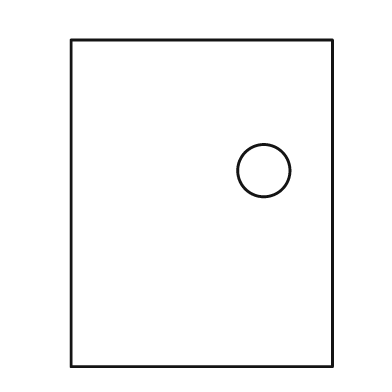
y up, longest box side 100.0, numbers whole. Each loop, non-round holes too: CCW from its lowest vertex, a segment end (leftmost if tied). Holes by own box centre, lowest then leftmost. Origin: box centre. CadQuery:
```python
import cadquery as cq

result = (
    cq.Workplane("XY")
    .moveTo(-40.0, -50.0)
    .lineTo(40.0, -50.0)
    .lineTo(40.0, 50.0)
    .lineTo(-40.0, 50.0)
    .close()
    .moveTo(19.0, 10.0)
    .circle(8.0)
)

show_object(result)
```